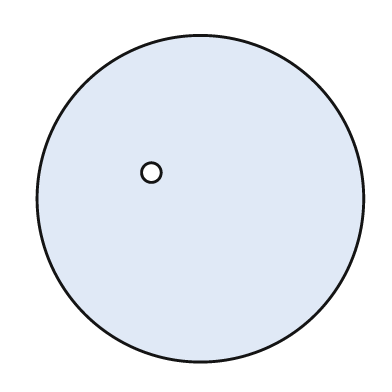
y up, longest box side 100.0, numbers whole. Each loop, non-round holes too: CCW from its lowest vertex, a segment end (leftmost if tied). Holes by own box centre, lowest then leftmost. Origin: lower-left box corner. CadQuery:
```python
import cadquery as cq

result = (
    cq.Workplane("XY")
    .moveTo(50.0, 50.0)
    .circle(50.0)
    .moveTo(35.0, 58.0)
    .circle(3.0)
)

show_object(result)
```